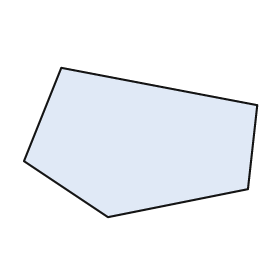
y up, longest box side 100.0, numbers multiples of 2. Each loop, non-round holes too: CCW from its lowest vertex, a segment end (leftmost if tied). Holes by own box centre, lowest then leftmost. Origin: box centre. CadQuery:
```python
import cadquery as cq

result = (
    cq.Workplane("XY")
    .moveTo(-14.0, -32.0)
    .lineTo(46.0, -20.0)
    .lineTo(50.0, 16.0)
    .lineTo(-34.0, 32.0)
    .lineTo(-50.0, -8.0)
    .close()
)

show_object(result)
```